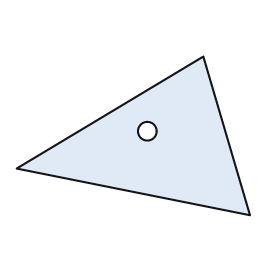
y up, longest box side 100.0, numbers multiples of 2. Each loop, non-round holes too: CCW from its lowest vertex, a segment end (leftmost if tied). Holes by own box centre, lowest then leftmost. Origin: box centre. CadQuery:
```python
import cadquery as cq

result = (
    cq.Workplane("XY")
    .moveTo(50.0, -34.0)
    .lineTo(30.0, 34.0)
    .lineTo(-50.0, -14.0)
    .close()
    .moveTo(6.0, 2.0)
    .circle(4.0)
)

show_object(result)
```